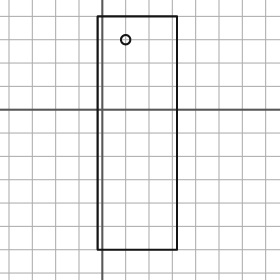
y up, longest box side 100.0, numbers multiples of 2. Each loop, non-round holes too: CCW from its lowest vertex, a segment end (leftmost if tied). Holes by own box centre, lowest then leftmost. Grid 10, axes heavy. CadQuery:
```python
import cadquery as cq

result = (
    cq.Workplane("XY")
    .moveTo(-2.0, -60.0)
    .lineTo(32.0, -60.0)
    .lineTo(32.0, 40.0)
    .lineTo(-2.0, 40.0)
    .close()
    .moveTo(10.0, 30.0)
    .circle(2.0)
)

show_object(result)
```